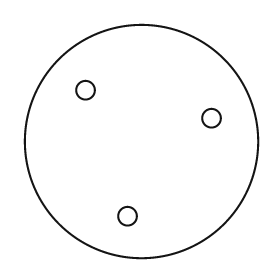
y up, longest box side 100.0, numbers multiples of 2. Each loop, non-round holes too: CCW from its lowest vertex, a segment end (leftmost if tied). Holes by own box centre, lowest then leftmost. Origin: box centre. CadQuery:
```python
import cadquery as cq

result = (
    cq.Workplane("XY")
    .moveTo(0.0, 0.0)
    .circle(50.0)
    .moveTo(-6.0, -32.0)
    .circle(4.0)
    .moveTo(30.0, 10.0)
    .circle(4.0)
    .moveTo(-24.0, 22.0)
    .circle(4.0)
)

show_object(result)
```